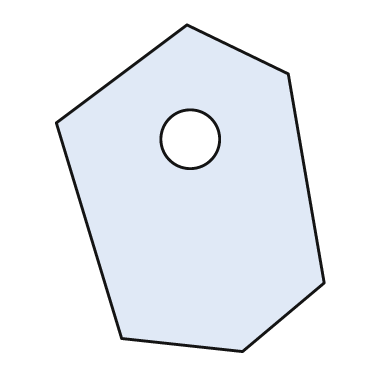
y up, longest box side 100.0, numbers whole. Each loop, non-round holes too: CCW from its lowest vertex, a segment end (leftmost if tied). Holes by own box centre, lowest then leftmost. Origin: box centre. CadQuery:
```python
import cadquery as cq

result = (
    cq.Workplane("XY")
    .moveTo(16.0, -50.0)
    .lineTo(41.0, -29.0)
    .lineTo(30.0, 35.0)
    .lineTo(-1.0, 50.0)
    .lineTo(-41.0, 20.0)
    .lineTo(-21.0, -46.0)
    .close()
    .moveTo(0.0, 15.0)
    .circle(9.0)
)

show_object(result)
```